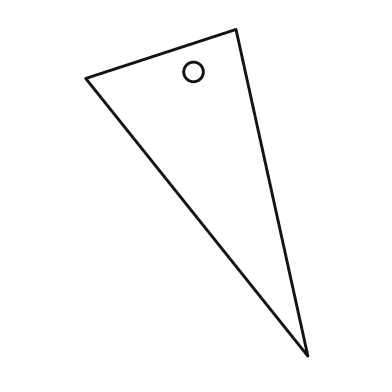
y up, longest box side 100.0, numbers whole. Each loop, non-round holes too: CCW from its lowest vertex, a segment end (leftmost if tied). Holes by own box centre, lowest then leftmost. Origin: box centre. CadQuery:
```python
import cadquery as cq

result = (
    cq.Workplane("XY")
    .moveTo(34.0, -50.0)
    .lineTo(12.0, 50.0)
    .lineTo(-34.0, 35.0)
    .close()
    .moveTo(-1.0, 37.0)
    .circle(3.0)
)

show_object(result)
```